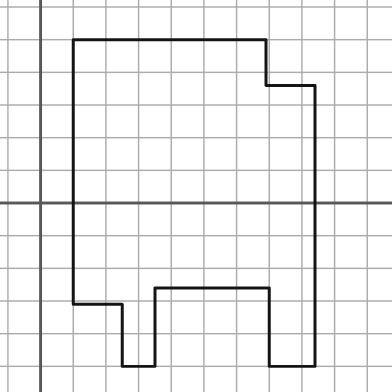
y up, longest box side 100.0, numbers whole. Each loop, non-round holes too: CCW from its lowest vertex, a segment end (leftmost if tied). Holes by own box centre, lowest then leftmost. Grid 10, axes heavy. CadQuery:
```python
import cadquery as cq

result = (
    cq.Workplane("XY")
    .moveTo(25.0, -50.0)
    .lineTo(35.0, -50.0)
    .lineTo(35.0, -26.0)
    .lineTo(70.0, -26.0)
    .lineTo(70.0, -50.0)
    .lineTo(84.0, -50.0)
    .lineTo(84.0, 36.0)
    .lineTo(69.0, 36.0)
    .lineTo(69.0, 50.0)
    .lineTo(10.0, 50.0)
    .lineTo(10.0, -31.0)
    .lineTo(25.0, -31.0)
    .close()
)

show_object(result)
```